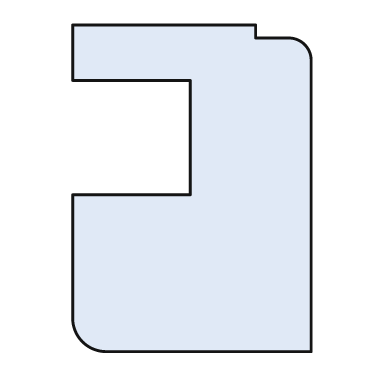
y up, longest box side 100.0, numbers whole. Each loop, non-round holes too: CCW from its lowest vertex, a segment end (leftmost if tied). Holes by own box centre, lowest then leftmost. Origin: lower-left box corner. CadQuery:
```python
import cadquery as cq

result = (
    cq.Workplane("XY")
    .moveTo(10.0, 0.0)
    .lineTo(73.0, 0.0)
    .lineTo(73.0, 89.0)
    .threePointArc((71.0, 94.0), (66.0, 96.0))
    .lineTo(56.0, 96.0)
    .lineTo(56.0, 100.0)
    .lineTo(0.0, 100.0)
    .lineTo(0.0, 83.0)
    .lineTo(36.0, 83.0)
    .lineTo(36.0, 48.0)
    .lineTo(0.0, 48.0)
    .lineTo(0.0, 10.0)
    .threePointArc((3.0, 3.0), (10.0, 0.0))
    .close()
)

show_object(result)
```